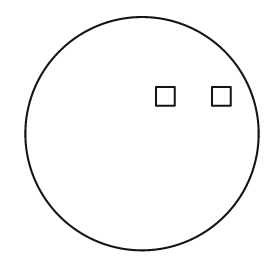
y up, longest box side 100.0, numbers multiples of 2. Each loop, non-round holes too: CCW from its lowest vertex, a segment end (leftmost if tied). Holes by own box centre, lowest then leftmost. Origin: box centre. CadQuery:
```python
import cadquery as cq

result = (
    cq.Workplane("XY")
    .moveTo(0.0, 0.0)
    .circle(50.0)
    .moveTo(6.0, 12.0)
    .lineTo(14.0, 12.0)
    .lineTo(14.0, 20.0)
    .lineTo(6.0, 20.0)
    .close()
    .moveTo(30.0, 12.0)
    .lineTo(38.0, 12.0)
    .lineTo(38.0, 20.0)
    .lineTo(30.0, 20.0)
    .close()
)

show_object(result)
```